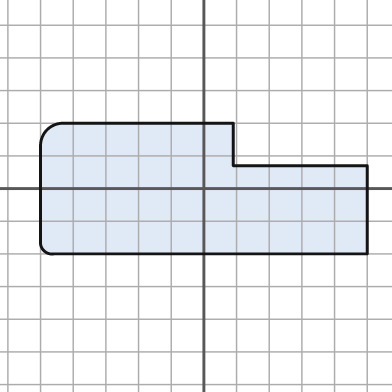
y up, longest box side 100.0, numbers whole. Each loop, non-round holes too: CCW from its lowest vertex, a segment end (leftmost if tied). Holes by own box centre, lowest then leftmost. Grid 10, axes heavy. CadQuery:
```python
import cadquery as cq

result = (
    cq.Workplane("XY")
    .moveTo(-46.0, -20.0)
    .lineTo(50.0, -20.0)
    .lineTo(50.0, 7.0)
    .lineTo(9.0, 7.0)
    .lineTo(9.0, 20.0)
    .lineTo(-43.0, 20.0)
    .threePointArc((-48.0, 18.0), (-50.0, 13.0))
    .lineTo(-50.0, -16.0)
    .threePointArc((-49.0, -19.0), (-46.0, -20.0))
    .close()
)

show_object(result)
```